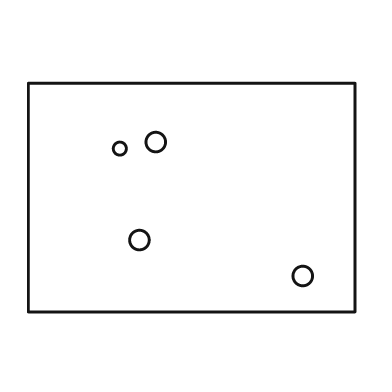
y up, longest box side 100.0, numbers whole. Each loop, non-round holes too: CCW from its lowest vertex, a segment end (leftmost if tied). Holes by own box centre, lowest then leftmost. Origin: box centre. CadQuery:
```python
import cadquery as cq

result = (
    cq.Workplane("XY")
    .moveTo(-50.0, -35.0)
    .lineTo(50.0, -35.0)
    .lineTo(50.0, 35.0)
    .lineTo(-50.0, 35.0)
    .close()
    .moveTo(34.0, -24.0)
    .circle(3.0)
    .moveTo(-16.0, -13.0)
    .circle(3.0)
    .moveTo(-22.0, 15.0)
    .circle(2.0)
    .moveTo(-11.0, 17.0)
    .circle(3.0)
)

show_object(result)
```